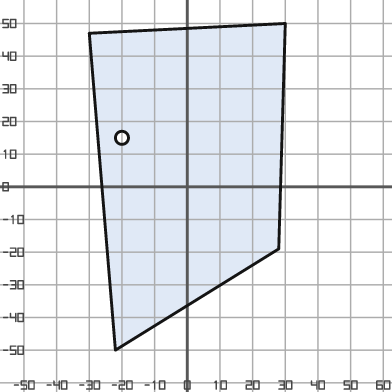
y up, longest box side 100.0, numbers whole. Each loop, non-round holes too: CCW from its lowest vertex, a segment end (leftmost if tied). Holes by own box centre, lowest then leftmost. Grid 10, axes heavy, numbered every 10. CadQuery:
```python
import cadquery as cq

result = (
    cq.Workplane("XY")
    .moveTo(-22.0, -50.0)
    .lineTo(28.0, -19.0)
    .lineTo(30.0, 50.0)
    .lineTo(-30.0, 47.0)
    .close()
    .moveTo(-20.0, 15.0)
    .circle(2.0)
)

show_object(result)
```